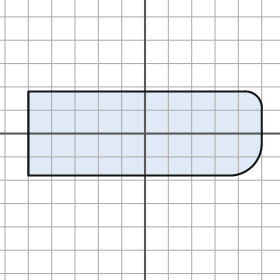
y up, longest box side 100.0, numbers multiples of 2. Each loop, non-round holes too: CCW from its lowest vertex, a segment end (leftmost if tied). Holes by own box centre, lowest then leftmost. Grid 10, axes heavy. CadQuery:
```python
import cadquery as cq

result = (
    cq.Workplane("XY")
    .moveTo(-50.0, -18.0)
    .lineTo(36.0, -18.0)
    .threePointArc((46.0, -14.0), (50.0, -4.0))
    .lineTo(50.0, 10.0)
    .threePointArc((48.0, 16.0), (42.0, 18.0))
    .lineTo(-50.0, 18.0)
    .close()
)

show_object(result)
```